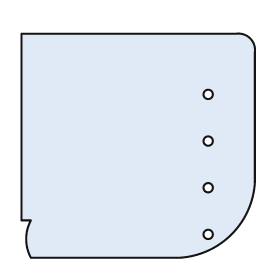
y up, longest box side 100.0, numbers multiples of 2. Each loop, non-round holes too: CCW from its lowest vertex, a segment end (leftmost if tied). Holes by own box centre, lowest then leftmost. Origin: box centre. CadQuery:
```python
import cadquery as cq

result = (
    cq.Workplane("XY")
    .moveTo(-46.0, -48.0)
    .lineTo(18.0, -48.0)
    .threePointArc((40.0, -38.0), (50.0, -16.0))
    .lineTo(50.0, 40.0)
    .threePointArc((48.0, 46.0), (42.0, 48.0))
    .lineTo(-50.0, 48.0)
    .lineTo(-50.0, -32.0)
    .lineTo(-46.0, -32.0)
    .threePointArc((-48.0, -40.0), (-46.0, -48.0))
    .close()
    .moveTo(30.0, -38.0)
    .circle(2.0)
    .moveTo(30.0, -18.0)
    .circle(2.0)
    .moveTo(30.0, 2.0)
    .circle(2.0)
    .moveTo(30.0, 22.0)
    .circle(2.0)
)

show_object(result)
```